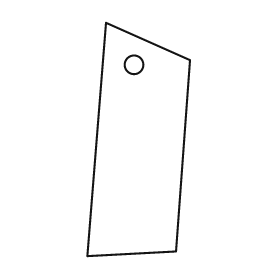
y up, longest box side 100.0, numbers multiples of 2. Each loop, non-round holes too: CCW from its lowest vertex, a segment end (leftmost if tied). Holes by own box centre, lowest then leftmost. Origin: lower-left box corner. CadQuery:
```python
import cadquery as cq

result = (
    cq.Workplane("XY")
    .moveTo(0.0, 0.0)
    .lineTo(38.0, 2.0)
    .lineTo(44.0, 84.0)
    .lineTo(8.0, 100.0)
    .close()
    .moveTo(20.0, 82.0)
    .circle(4.0)
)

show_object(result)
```